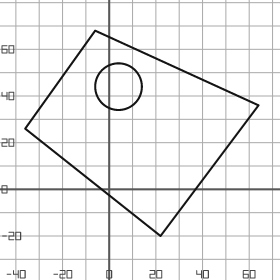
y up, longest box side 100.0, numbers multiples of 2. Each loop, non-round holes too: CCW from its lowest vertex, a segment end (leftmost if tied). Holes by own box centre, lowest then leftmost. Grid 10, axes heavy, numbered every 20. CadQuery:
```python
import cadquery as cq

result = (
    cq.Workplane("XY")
    .moveTo(22.0, -20.0)
    .lineTo(64.0, 36.0)
    .lineTo(-6.0, 68.0)
    .lineTo(-36.0, 26.0)
    .close()
    .moveTo(4.0, 44.0)
    .circle(10.0)
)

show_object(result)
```